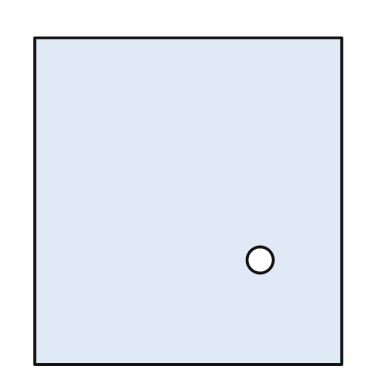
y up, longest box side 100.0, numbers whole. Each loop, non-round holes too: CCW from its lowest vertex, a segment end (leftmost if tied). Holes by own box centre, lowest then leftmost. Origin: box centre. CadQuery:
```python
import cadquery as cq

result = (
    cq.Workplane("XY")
    .moveTo(-47.0, -50.0)
    .lineTo(47.0, -50.0)
    .lineTo(47.0, 50.0)
    .lineTo(-47.0, 50.0)
    .close()
    .moveTo(22.0, -18.0)
    .circle(4.0)
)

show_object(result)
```